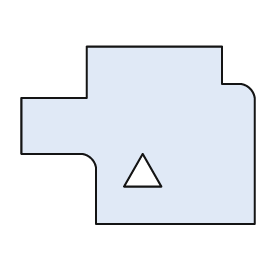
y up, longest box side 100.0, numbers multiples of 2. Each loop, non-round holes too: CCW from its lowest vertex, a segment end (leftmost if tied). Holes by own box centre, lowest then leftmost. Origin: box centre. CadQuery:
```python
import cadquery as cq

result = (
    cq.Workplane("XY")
    .moveTo(-18.0, -38.0)
    .lineTo(50.0, -38.0)
    .lineTo(50.0, 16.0)
    .threePointArc((48.0, 20.0), (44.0, 22.0))
    .lineTo(36.0, 22.0)
    .lineTo(36.0, 38.0)
    .lineTo(-22.0, 38.0)
    .lineTo(-22.0, 16.0)
    .lineTo(-50.0, 16.0)
    .lineTo(-50.0, -8.0)
    .lineTo(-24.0, -8.0)
    .threePointArc((-20.0, -10.0), (-18.0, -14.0))
    .close()
    .moveTo(-6.0, -22.0)
    .lineTo(10.0, -22.0)
    .lineTo(2.0, -8.0)
    .close()
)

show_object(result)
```